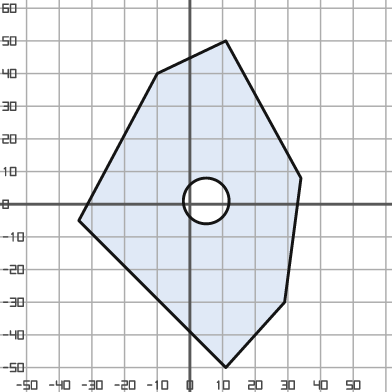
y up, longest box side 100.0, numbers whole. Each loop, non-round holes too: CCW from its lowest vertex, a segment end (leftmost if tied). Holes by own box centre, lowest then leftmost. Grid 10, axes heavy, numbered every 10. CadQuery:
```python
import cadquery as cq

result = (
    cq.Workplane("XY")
    .moveTo(11.0, -50.0)
    .lineTo(29.0, -30.0)
    .lineTo(34.0, 8.0)
    .lineTo(11.0, 50.0)
    .lineTo(-10.0, 40.0)
    .lineTo(-34.0, -5.0)
    .close()
    .moveTo(5.0, 1.0)
    .circle(7.0)
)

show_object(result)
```